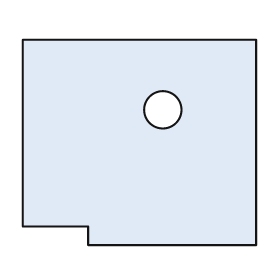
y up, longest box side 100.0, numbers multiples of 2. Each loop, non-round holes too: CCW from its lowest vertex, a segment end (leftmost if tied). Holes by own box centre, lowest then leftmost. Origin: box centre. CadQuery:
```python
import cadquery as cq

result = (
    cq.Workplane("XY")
    .moveTo(-22.0, -44.0)
    .lineTo(50.0, -44.0)
    .lineTo(50.0, 44.0)
    .lineTo(-50.0, 44.0)
    .lineTo(-50.0, -36.0)
    .lineTo(-22.0, -36.0)
    .close()
    .moveTo(10.0, 14.0)
    .circle(8.0)
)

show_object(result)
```